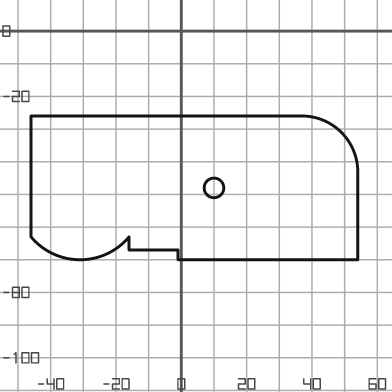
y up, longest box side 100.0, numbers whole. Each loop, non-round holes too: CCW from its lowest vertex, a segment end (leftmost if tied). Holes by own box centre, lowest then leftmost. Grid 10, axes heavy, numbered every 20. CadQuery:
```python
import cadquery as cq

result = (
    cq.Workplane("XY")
    .moveTo(-1.0, -70.0)
    .lineTo(54.0, -70.0)
    .lineTo(54.0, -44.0)
    .threePointArc((49.0, -31.0), (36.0, -26.0))
    .lineTo(-46.0, -26.0)
    .lineTo(-46.0, -63.0)
    .threePointArc((-31.0, -70.0), (-16.0, -63.0))
    .lineTo(-16.0, -67.0)
    .lineTo(-1.0, -67.0)
    .close()
    .moveTo(10.0, -48.0)
    .circle(3.0)
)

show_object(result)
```